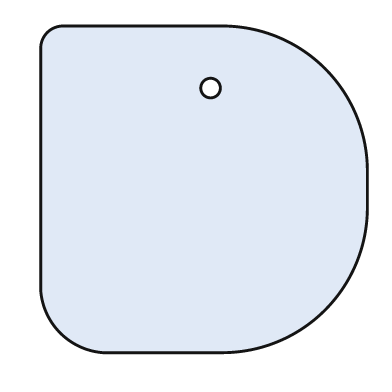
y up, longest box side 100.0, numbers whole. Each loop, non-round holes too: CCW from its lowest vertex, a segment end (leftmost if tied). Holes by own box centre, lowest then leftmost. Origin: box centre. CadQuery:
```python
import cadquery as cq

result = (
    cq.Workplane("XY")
    .moveTo(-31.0, -50.0)
    .lineTo(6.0, -50.0)
    .threePointArc((37.0, -37.0), (50.0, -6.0))
    .lineTo(50.0, 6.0)
    .threePointArc((37.0, 37.0), (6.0, 50.0))
    .lineTo(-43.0, 50.0)
    .threePointArc((-48.0, 48.0), (-50.0, 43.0))
    .lineTo(-50.0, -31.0)
    .threePointArc((-44.0, -44.0), (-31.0, -50.0))
    .close()
    .moveTo(2.0, 31.0)
    .circle(3.0)
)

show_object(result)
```